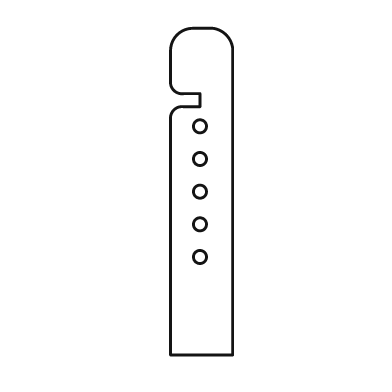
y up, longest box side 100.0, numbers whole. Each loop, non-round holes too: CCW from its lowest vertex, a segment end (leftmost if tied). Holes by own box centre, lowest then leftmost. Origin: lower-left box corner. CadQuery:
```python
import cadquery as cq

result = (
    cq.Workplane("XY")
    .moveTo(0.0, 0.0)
    .lineTo(19.0, 0.0)
    .lineTo(19.0, 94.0)
    .threePointArc((17.0, 98.0), (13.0, 100.0))
    .lineTo(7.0, 100.0)
    .threePointArc((2.0, 98.0), (0.0, 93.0))
    .lineTo(0.0, 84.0)
    .threePointArc((1.0, 81.0), (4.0, 80.0))
    .lineTo(9.0, 80.0)
    .lineTo(9.0, 76.0)
    .lineTo(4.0, 76.0)
    .threePointArc((1.0, 75.0), (0.0, 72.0))
    .close()
    .moveTo(9.0, 30.0)
    .circle(2.0)
    .moveTo(9.0, 40.0)
    .circle(2.0)
    .moveTo(9.0, 50.0)
    .circle(2.0)
    .moveTo(9.0, 60.0)
    .circle(2.0)
    .moveTo(9.0, 70.0)
    .circle(2.0)
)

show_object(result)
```